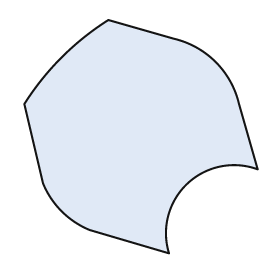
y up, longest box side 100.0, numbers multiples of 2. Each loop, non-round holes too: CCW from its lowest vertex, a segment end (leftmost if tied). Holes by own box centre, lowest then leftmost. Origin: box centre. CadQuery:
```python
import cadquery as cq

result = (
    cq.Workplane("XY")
    .moveTo(12.0, -50.0)
    .threePointArc((20.0, -20.0), (50.0, -14.0))
    .lineTo(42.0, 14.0)
    .threePointArc((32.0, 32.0), (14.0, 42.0))
    .lineTo(-14.0, 50.0)
    .threePointArc((-34.0, 34.0), (-50.0, 14.0))
    .lineTo(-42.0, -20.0)
    .threePointArc((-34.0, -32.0), (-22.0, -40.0))
    .close()
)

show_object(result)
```